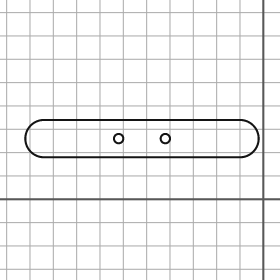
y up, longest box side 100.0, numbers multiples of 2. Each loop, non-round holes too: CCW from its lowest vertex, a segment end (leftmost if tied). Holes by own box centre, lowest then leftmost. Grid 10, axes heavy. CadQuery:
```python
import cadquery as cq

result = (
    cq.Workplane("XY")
    .moveTo(-94.0, 18.0)
    .lineTo(-10.0, 18.0)
    .threePointArc((-2.0, 26.0), (-10.0, 34.0))
    .lineTo(-94.0, 34.0)
    .threePointArc((-102.0, 26.0), (-94.0, 18.0))
    .close()
    .moveTo(-62.0, 26.0)
    .circle(2.0)
    .moveTo(-42.0, 26.0)
    .circle(2.0)
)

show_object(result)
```